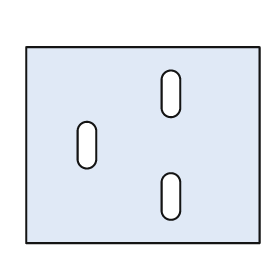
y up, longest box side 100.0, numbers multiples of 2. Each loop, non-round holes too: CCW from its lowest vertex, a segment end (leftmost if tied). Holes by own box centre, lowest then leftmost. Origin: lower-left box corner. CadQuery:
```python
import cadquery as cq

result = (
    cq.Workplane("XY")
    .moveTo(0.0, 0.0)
    .lineTo(100.0, 0.0)
    .lineTo(100.0, 84.0)
    .lineTo(0.0, 84.0)
    .close()
    .moveTo(58.0, 14.0)
    .threePointArc((62.0, 10.0), (66.0, 14.0))
    .lineTo(66.0, 26.0)
    .threePointArc((62.0, 30.0), (58.0, 26.0))
    .close()
    .moveTo(22.0, 36.0)
    .threePointArc((26.0, 32.0), (30.0, 36.0))
    .lineTo(30.0, 48.0)
    .threePointArc((26.0, 52.0), (22.0, 48.0))
    .close()
    .moveTo(58.0, 58.0)
    .threePointArc((62.0, 54.0), (66.0, 58.0))
    .lineTo(66.0, 70.0)
    .threePointArc((62.0, 74.0), (58.0, 70.0))
    .close()
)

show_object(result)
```